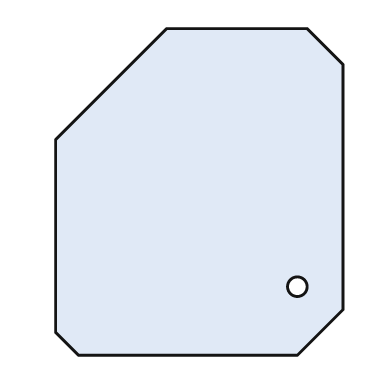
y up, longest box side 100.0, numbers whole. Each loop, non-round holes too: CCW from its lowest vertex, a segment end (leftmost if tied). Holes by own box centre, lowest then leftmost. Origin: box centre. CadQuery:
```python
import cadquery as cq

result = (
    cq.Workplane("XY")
    .moveTo(-37.0, -50.0)
    .lineTo(30.0, -50.0)
    .lineTo(44.0, -36.0)
    .lineTo(44.0, 39.0)
    .lineTo(33.0, 50.0)
    .lineTo(-10.0, 50.0)
    .lineTo(-44.0, 16.0)
    .lineTo(-44.0, -43.0)
    .close()
    .moveTo(30.0, -29.0)
    .circle(3.0)
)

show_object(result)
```